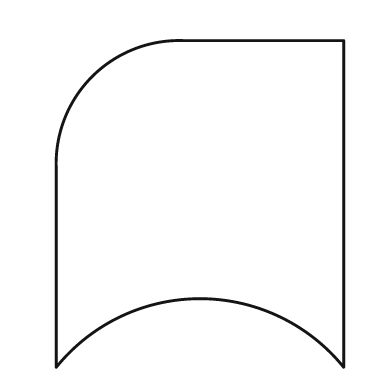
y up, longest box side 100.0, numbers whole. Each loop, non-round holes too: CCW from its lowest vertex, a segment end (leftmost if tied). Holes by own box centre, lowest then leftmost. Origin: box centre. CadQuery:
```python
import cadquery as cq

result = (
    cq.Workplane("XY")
    .moveTo(-44.0, -50.0)
    .threePointArc((0.0, -29.0), (44.0, -50.0))
    .lineTo(44.0, 50.0)
    .lineTo(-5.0, 50.0)
    .threePointArc((-33.0, 39.0), (-44.0, 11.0))
    .close()
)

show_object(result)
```